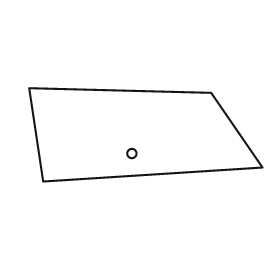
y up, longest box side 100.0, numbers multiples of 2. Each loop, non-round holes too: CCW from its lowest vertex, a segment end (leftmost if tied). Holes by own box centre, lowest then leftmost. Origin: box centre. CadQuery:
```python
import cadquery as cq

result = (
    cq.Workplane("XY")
    .moveTo(-44.0, -20.0)
    .lineTo(50.0, -14.0)
    .lineTo(28.0, 18.0)
    .lineTo(-50.0, 20.0)
    .close()
    .moveTo(-6.0, -8.0)
    .circle(2.0)
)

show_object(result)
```